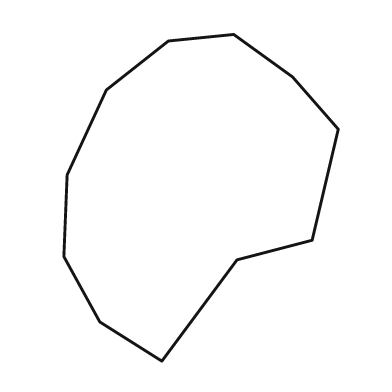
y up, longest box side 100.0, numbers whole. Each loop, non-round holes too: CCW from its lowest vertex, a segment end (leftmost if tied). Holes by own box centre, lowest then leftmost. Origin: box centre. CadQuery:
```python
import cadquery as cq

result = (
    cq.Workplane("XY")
    .moveTo(-12.0, -50.0)
    .lineTo(11.0, -19.0)
    .lineTo(34.0, -13.0)
    .lineTo(42.0, 21.0)
    .lineTo(28.0, 37.0)
    .lineTo(10.0, 50.0)
    .lineTo(-10.0, 48.0)
    .lineTo(-29.0, 33.0)
    .lineTo(-41.0, 7.0)
    .lineTo(-42.0, -18.0)
    .lineTo(-31.0, -38.0)
    .close()
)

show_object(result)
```